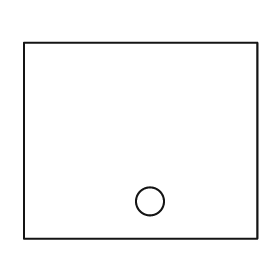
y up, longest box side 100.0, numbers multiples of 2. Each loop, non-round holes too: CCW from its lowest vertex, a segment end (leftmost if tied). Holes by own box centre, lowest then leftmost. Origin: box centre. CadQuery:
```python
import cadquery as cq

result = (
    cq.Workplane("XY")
    .moveTo(-50.0, -42.0)
    .lineTo(50.0, -42.0)
    .lineTo(50.0, 42.0)
    .lineTo(-50.0, 42.0)
    .close()
    .moveTo(4.0, -26.0)
    .circle(6.0)
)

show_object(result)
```